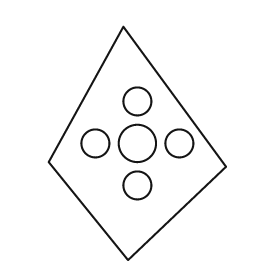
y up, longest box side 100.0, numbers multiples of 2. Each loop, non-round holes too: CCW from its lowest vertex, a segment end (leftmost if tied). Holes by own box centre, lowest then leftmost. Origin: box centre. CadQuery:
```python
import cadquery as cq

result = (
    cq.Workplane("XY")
    .moveTo(-4.0, -50.0)
    .lineTo(38.0, -10.0)
    .lineTo(-6.0, 50.0)
    .lineTo(-38.0, -8.0)
    .close()
    .moveTo(0.0, -18.0)
    .circle(6.0)
    .moveTo(-18.0, 0.0)
    .circle(6.0)
    .moveTo(0.0, 0.0)
    .circle(8.0)
    .moveTo(18.0, 0.0)
    .circle(6.0)
    .moveTo(0.0, 18.0)
    .circle(6.0)
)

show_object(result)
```